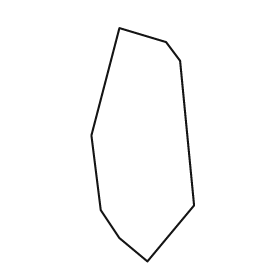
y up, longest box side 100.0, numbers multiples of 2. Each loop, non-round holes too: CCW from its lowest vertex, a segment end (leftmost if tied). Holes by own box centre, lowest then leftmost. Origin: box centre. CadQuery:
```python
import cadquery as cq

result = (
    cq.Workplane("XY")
    .moveTo(2.0, -50.0)
    .lineTo(22.0, -26.0)
    .lineTo(16.0, 36.0)
    .lineTo(10.0, 44.0)
    .lineTo(-10.0, 50.0)
    .lineTo(-22.0, 4.0)
    .lineTo(-18.0, -28.0)
    .lineTo(-10.0, -40.0)
    .close()
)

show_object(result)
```